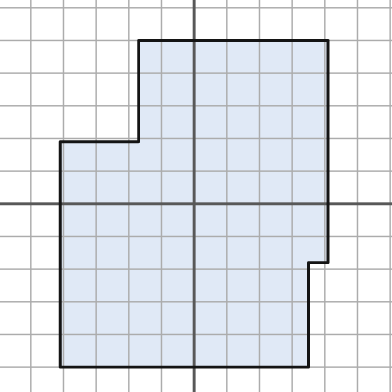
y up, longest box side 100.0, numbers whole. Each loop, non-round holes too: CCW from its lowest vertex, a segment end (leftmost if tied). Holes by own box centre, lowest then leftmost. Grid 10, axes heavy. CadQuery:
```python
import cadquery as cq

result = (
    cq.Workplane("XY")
    .moveTo(-41.0, -50.0)
    .lineTo(35.0, -50.0)
    .lineTo(35.0, -18.0)
    .lineTo(41.0, -18.0)
    .lineTo(41.0, 50.0)
    .lineTo(-17.0, 50.0)
    .lineTo(-17.0, 19.0)
    .lineTo(-41.0, 19.0)
    .close()
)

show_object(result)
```